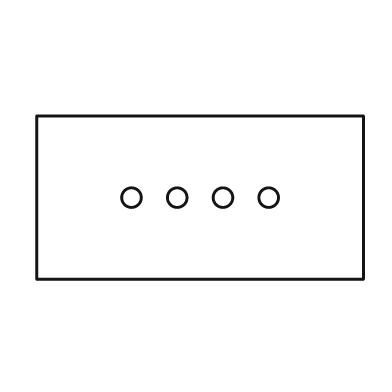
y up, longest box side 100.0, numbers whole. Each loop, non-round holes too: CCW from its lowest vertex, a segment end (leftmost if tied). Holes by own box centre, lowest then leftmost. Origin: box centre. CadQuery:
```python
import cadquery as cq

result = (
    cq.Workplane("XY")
    .moveTo(-50.0, -25.0)
    .lineTo(50.0, -25.0)
    .lineTo(50.0, 25.0)
    .lineTo(-50.0, 25.0)
    .close()
    .moveTo(-21.0, 0.0)
    .circle(3.0)
    .moveTo(-7.0, 0.0)
    .circle(3.0)
    .moveTo(7.0, 0.0)
    .circle(3.0)
    .moveTo(21.0, 0.0)
    .circle(3.0)
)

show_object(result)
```